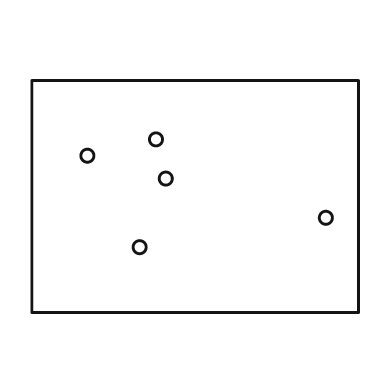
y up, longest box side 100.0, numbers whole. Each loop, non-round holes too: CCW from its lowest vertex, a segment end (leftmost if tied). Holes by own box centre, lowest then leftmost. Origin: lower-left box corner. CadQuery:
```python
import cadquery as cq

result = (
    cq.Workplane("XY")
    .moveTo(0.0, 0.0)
    .lineTo(100.0, 0.0)
    .lineTo(100.0, 71.0)
    .lineTo(0.0, 71.0)
    .close()
    .moveTo(33.0, 20.0)
    .circle(2.0)
    .moveTo(90.0, 29.0)
    .circle(2.0)
    .moveTo(41.0, 41.0)
    .circle(2.0)
    .moveTo(17.0, 48.0)
    .circle(2.0)
    .moveTo(38.0, 53.0)
    .circle(2.0)
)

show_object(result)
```